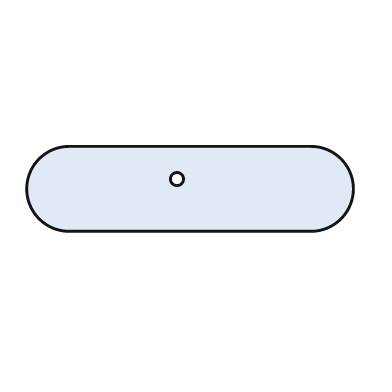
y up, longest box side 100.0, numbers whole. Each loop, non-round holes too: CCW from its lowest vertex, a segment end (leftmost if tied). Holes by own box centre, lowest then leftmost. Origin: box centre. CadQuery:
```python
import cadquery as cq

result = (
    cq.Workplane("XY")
    .moveTo(-37.0, -13.0)
    .lineTo(37.0, -13.0)
    .threePointArc((50.0, 0.0), (37.0, 13.0))
    .lineTo(-37.0, 13.0)
    .threePointArc((-50.0, 0.0), (-37.0, -13.0))
    .close()
    .moveTo(-4.0, 3.0)
    .circle(2.0)
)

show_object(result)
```